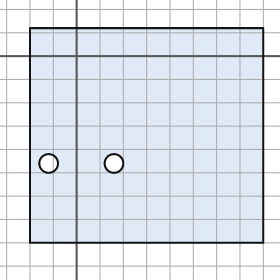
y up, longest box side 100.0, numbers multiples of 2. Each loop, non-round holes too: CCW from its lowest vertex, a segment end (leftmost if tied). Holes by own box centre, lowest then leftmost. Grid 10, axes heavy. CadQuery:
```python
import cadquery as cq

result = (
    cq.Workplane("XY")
    .moveTo(-20.0, -80.0)
    .lineTo(80.0, -80.0)
    .lineTo(80.0, 12.0)
    .lineTo(-20.0, 12.0)
    .close()
    .moveTo(-12.0, -46.0)
    .circle(4.0)
    .moveTo(16.0, -46.0)
    .circle(4.0)
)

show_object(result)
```